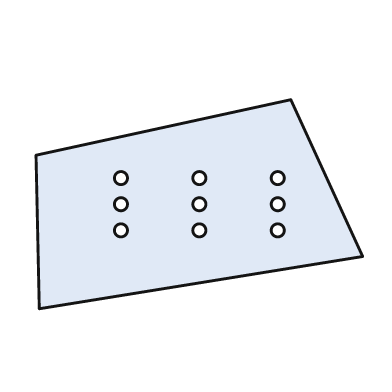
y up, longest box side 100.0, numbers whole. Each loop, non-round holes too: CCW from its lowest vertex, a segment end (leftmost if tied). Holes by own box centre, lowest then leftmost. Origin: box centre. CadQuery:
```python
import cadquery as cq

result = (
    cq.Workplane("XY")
    .moveTo(-49.0, -32.0)
    .lineTo(50.0, -16.0)
    .lineTo(28.0, 32.0)
    .lineTo(-50.0, 15.0)
    .close()
    .moveTo(-24.0, -8.0)
    .circle(2.0)
    .moveTo(0.0, -8.0)
    .circle(2.0)
    .moveTo(24.0, -8.0)
    .circle(2.0)
    .moveTo(-24.0, 0.0)
    .circle(2.0)
    .moveTo(0.0, 0.0)
    .circle(2.0)
    .moveTo(24.0, 0.0)
    .circle(2.0)
    .moveTo(-24.0, 8.0)
    .circle(2.0)
    .moveTo(0.0, 8.0)
    .circle(2.0)
    .moveTo(24.0, 8.0)
    .circle(2.0)
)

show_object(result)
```